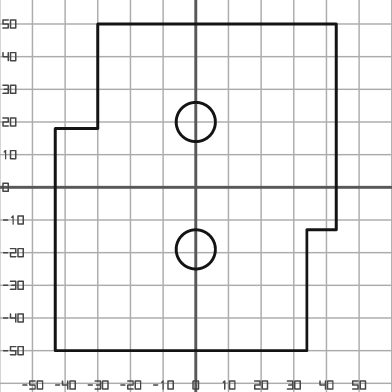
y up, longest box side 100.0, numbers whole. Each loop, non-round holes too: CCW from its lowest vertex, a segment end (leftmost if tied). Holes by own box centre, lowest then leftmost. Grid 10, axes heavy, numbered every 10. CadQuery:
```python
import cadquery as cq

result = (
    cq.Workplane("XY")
    .moveTo(-43.0, -50.0)
    .lineTo(34.0, -50.0)
    .lineTo(34.0, -13.0)
    .lineTo(43.0, -13.0)
    .lineTo(43.0, 50.0)
    .lineTo(-30.0, 50.0)
    .lineTo(-30.0, 18.0)
    .lineTo(-43.0, 18.0)
    .close()
    .moveTo(0.0, -19.0)
    .circle(6.0)
    .moveTo(0.0, 20.0)
    .circle(6.0)
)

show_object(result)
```